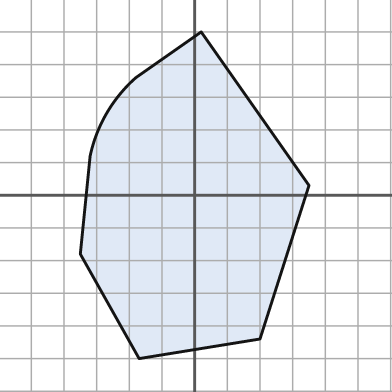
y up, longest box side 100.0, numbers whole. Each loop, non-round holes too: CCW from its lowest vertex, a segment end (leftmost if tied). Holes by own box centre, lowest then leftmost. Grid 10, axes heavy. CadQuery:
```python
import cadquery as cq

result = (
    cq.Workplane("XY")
    .moveTo(-17.0, -50.0)
    .lineTo(20.0, -44.0)
    .lineTo(35.0, 3.0)
    .lineTo(2.0, 50.0)
    .lineTo(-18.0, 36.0)
    .threePointArc((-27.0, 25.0), (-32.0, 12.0))
    .lineTo(-35.0, -18.0)
    .close()
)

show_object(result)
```